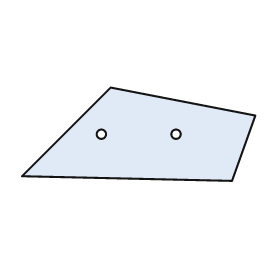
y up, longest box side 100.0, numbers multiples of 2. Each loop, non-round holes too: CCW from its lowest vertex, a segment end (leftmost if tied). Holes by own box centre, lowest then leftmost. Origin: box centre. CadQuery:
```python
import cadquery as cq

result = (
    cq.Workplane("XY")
    .moveTo(40.0, -20.0)
    .lineTo(50.0, 8.0)
    .lineTo(-12.0, 20.0)
    .lineTo(-50.0, -18.0)
    .close()
    .moveTo(-16.0, 0.0)
    .circle(2.0)
    .moveTo(16.0, 0.0)
    .circle(2.0)
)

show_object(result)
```